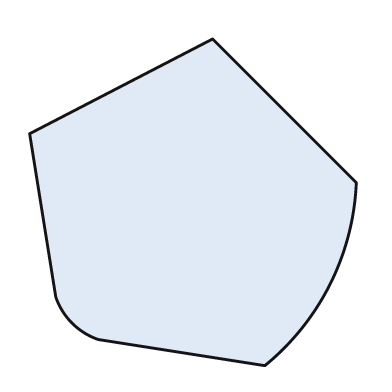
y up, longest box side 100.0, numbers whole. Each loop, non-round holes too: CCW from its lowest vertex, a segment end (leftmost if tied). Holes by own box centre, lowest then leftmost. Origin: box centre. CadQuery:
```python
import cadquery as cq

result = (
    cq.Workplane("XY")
    .moveTo(22.0, -50.0)
    .threePointArc((42.0, -25.0), (50.0, 6.0))
    .lineTo(6.0, 50.0)
    .lineTo(-50.0, 21.0)
    .lineTo(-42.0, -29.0)
    .threePointArc((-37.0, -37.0), (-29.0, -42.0))
    .close()
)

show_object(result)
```